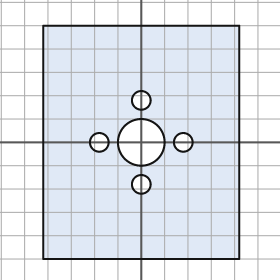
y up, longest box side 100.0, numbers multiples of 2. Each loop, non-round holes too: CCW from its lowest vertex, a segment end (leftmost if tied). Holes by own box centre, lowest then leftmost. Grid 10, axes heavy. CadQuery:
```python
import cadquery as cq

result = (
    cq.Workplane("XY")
    .moveTo(-42.0, -50.0)
    .lineTo(42.0, -50.0)
    .lineTo(42.0, 50.0)
    .lineTo(-42.0, 50.0)
    .close()
    .moveTo(0.0, -18.0)
    .circle(4.0)
    .moveTo(-18.0, 0.0)
    .circle(4.0)
    .moveTo(0.0, 0.0)
    .circle(10.0)
    .moveTo(18.0, 0.0)
    .circle(4.0)
    .moveTo(0.0, 18.0)
    .circle(4.0)
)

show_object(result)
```